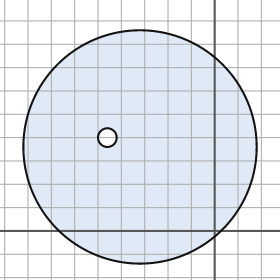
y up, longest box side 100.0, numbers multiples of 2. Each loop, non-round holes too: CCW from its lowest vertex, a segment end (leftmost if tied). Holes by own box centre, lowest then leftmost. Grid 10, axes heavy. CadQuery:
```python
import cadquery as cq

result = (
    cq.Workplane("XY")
    .moveTo(-32.0, 36.0)
    .circle(50.0)
    .moveTo(-46.0, 40.0)
    .circle(4.0)
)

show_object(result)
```